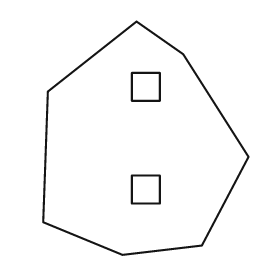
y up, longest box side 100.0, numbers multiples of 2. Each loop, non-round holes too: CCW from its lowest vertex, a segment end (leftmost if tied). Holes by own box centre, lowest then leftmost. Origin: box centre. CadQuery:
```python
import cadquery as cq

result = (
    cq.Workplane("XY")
    .moveTo(-10.0, -50.0)
    .lineTo(24.0, -46.0)
    .lineTo(44.0, -8.0)
    .lineTo(16.0, 36.0)
    .lineTo(-4.0, 50.0)
    .lineTo(-42.0, 20.0)
    .lineTo(-44.0, -36.0)
    .close()
    .moveTo(-6.0, -28.0)
    .lineTo(6.0, -28.0)
    .lineTo(6.0, -16.0)
    .lineTo(-6.0, -16.0)
    .close()
    .moveTo(-6.0, 16.0)
    .lineTo(6.0, 16.0)
    .lineTo(6.0, 28.0)
    .lineTo(-6.0, 28.0)
    .close()
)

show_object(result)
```